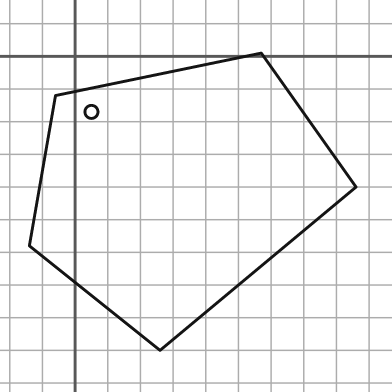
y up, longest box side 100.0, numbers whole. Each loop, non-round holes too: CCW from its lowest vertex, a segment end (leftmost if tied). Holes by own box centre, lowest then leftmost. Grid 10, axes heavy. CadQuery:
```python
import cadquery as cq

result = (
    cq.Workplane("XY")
    .moveTo(26.0, -90.0)
    .lineTo(86.0, -40.0)
    .lineTo(57.0, 1.0)
    .lineTo(-6.0, -12.0)
    .lineTo(-14.0, -58.0)
    .close()
    .moveTo(5.0, -17.0)
    .circle(2.0)
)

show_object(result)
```